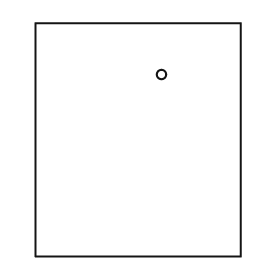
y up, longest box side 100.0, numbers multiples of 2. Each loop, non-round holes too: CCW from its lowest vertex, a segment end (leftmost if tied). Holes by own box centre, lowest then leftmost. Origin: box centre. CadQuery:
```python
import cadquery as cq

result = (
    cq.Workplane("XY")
    .moveTo(-44.0, -50.0)
    .lineTo(44.0, -50.0)
    .lineTo(44.0, 50.0)
    .lineTo(-44.0, 50.0)
    .close()
    .moveTo(10.0, 28.0)
    .circle(2.0)
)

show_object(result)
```